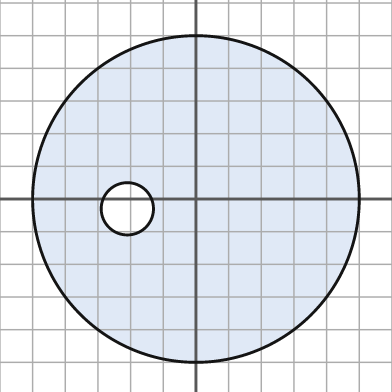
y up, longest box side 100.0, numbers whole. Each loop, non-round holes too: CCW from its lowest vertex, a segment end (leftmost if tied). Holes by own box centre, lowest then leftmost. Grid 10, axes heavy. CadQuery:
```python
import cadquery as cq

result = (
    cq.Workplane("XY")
    .moveTo(0.0, 0.0)
    .circle(50.0)
    .moveTo(-21.0, -3.0)
    .circle(8.0)
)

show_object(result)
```